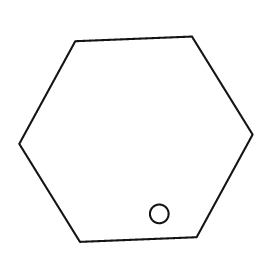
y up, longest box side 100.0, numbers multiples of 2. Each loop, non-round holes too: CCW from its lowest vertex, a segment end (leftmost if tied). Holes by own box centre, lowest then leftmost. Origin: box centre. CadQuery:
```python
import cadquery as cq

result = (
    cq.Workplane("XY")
    .moveTo(-24.0, -44.0)
    .lineTo(26.0, -42.0)
    .lineTo(50.0, 2.0)
    .lineTo(24.0, 44.0)
    .lineTo(-26.0, 42.0)
    .lineTo(-50.0, -2.0)
    .close()
    .moveTo(10.0, -32.0)
    .circle(4.0)
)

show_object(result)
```